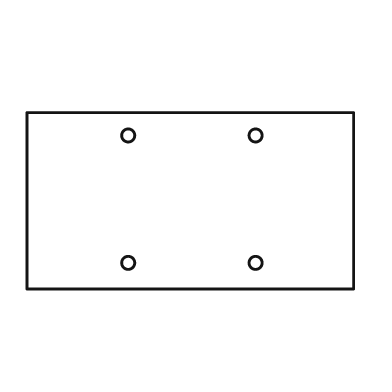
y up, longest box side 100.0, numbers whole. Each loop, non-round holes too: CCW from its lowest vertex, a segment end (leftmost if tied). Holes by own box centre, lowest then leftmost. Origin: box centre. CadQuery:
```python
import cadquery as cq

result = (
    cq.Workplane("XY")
    .moveTo(-50.0, -27.0)
    .lineTo(50.0, -27.0)
    .lineTo(50.0, 27.0)
    .lineTo(-50.0, 27.0)
    .close()
    .moveTo(-19.0, -19.0)
    .circle(2.0)
    .moveTo(20.0, -19.0)
    .circle(2.0)
    .moveTo(-19.0, 20.0)
    .circle(2.0)
    .moveTo(20.0, 20.0)
    .circle(2.0)
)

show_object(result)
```